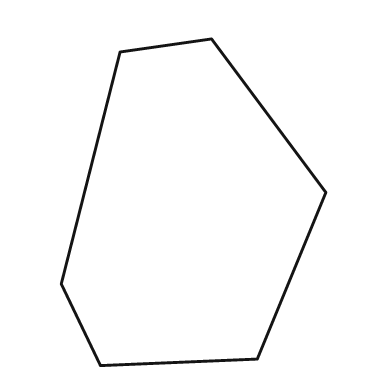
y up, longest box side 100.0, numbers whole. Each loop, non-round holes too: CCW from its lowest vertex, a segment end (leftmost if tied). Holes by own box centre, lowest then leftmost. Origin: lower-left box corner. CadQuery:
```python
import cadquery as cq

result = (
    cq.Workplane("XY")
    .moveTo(12.0, 0.0)
    .lineTo(60.0, 2.0)
    .lineTo(81.0, 53.0)
    .lineTo(46.0, 100.0)
    .lineTo(18.0, 96.0)
    .lineTo(0.0, 25.0)
    .close()
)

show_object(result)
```